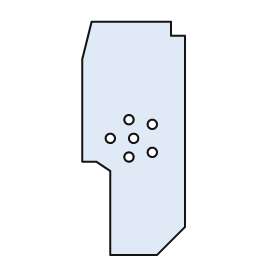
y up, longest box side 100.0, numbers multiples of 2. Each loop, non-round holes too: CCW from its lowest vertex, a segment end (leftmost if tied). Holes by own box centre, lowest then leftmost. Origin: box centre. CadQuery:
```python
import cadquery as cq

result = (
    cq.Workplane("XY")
    .moveTo(-10.0, -50.0)
    .lineTo(10.0, -50.0)
    .lineTo(22.0, -38.0)
    .lineTo(22.0, 44.0)
    .lineTo(16.0, 44.0)
    .lineTo(16.0, 50.0)
    .lineTo(-18.0, 50.0)
    .lineTo(-22.0, 34.0)
    .lineTo(-22.0, -10.0)
    .lineTo(-16.0, -10.0)
    .lineTo(-10.0, -14.0)
    .close()
    .moveTo(-2.0, -8.0)
    .circle(2.0)
    .moveTo(8.0, -6.0)
    .circle(2.0)
    .moveTo(-10.0, 0.0)
    .circle(2.0)
    .moveTo(0.0, 0.0)
    .circle(2.0)
    .moveTo(8.0, 6.0)
    .circle(2.0)
    .moveTo(-2.0, 8.0)
    .circle(2.0)
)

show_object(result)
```